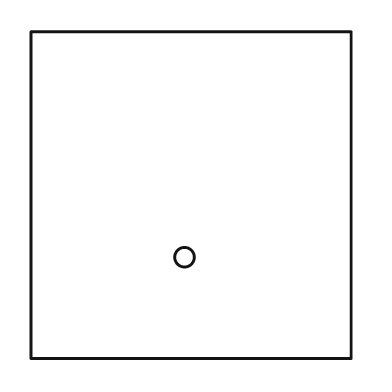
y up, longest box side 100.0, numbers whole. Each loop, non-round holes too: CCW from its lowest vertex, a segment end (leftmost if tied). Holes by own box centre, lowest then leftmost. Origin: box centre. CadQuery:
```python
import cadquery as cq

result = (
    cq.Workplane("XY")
    .moveTo(-49.0, -50.0)
    .lineTo(49.0, -50.0)
    .lineTo(49.0, 50.0)
    .lineTo(-49.0, 50.0)
    .close()
    .moveTo(-2.0, -19.0)
    .circle(3.0)
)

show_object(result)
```